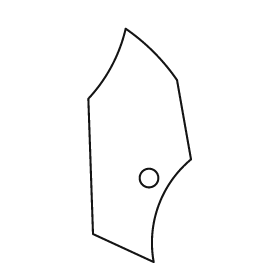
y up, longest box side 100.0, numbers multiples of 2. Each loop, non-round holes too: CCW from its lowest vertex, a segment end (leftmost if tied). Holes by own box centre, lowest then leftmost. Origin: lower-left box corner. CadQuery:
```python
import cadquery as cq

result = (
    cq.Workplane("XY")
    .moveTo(28.0, 0.0)
    .threePointArc((30.0, 24.0), (44.0, 44.0))
    .lineTo(38.0, 78.0)
    .threePointArc((28.0, 90.0), (16.0, 100.0))
    .threePointArc((10.0, 84.0), (0.0, 70.0))
    .lineTo(2.0, 12.0)
    .close()
    .moveTo(26.0, 36.0)
    .circle(4.0)
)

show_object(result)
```